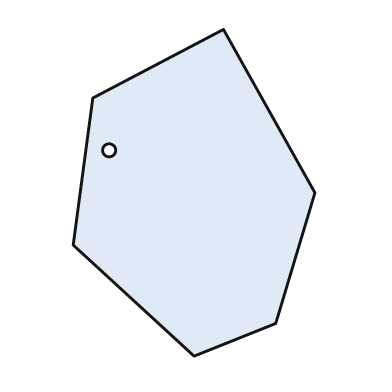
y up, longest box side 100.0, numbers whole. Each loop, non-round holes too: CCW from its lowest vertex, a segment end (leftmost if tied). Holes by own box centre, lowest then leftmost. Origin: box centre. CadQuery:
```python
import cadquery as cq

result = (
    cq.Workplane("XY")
    .moveTo(0.0, -50.0)
    .lineTo(25.0, -40.0)
    .lineTo(37.0, 0.0)
    .lineTo(9.0, 50.0)
    .lineTo(-31.0, 29.0)
    .lineTo(-37.0, -16.0)
    .close()
    .moveTo(-26.0, 13.0)
    .circle(2.0)
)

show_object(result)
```